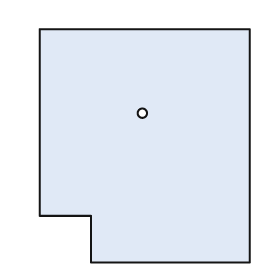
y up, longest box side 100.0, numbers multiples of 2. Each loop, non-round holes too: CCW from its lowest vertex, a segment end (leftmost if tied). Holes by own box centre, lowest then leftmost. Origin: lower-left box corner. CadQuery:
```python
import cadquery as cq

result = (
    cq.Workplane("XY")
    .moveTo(22.0, 0.0)
    .lineTo(90.0, 0.0)
    .lineTo(90.0, 100.0)
    .lineTo(0.0, 100.0)
    .lineTo(0.0, 20.0)
    .lineTo(22.0, 20.0)
    .close()
    .moveTo(44.0, 64.0)
    .circle(2.0)
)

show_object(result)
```